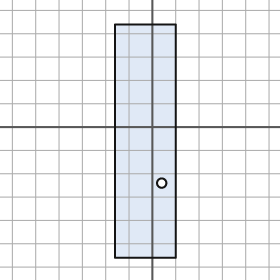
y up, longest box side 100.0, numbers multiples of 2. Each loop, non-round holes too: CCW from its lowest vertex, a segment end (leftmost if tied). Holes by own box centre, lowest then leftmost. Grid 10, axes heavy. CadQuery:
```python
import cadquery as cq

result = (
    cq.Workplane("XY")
    .moveTo(-16.0, -56.0)
    .lineTo(10.0, -56.0)
    .lineTo(10.0, 44.0)
    .lineTo(-16.0, 44.0)
    .close()
    .moveTo(4.0, -24.0)
    .circle(2.0)
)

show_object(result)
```